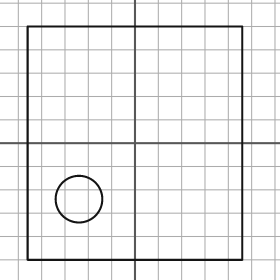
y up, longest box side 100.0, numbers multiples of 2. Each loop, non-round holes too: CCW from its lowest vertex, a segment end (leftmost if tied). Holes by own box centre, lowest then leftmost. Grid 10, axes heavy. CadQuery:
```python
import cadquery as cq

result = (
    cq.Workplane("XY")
    .moveTo(-46.0, -50.0)
    .lineTo(46.0, -50.0)
    .lineTo(46.0, 50.0)
    .lineTo(-46.0, 50.0)
    .close()
    .moveTo(-24.0, -24.0)
    .circle(10.0)
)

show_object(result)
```